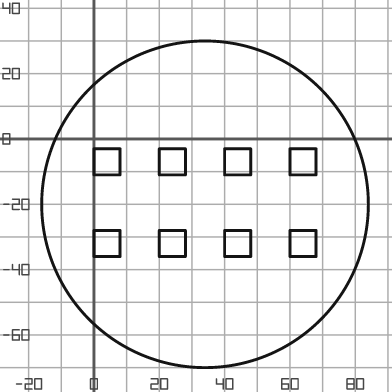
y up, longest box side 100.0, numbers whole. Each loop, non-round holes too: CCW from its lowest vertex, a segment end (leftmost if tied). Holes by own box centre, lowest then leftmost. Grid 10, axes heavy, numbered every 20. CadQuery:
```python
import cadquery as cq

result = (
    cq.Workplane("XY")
    .moveTo(34.0, -20.0)
    .circle(50.0)
    .moveTo(0.0, -36.0)
    .lineTo(8.0, -36.0)
    .lineTo(8.0, -28.0)
    .lineTo(0.0, -28.0)
    .close()
    .moveTo(20.0, -36.0)
    .lineTo(28.0, -36.0)
    .lineTo(28.0, -28.0)
    .lineTo(20.0, -28.0)
    .close()
    .moveTo(40.0, -36.0)
    .lineTo(48.0, -36.0)
    .lineTo(48.0, -28.0)
    .lineTo(40.0, -28.0)
    .close()
    .moveTo(60.0, -36.0)
    .lineTo(68.0, -36.0)
    .lineTo(68.0, -28.0)
    .lineTo(60.0, -28.0)
    .close()
    .moveTo(0.0, -11.0)
    .lineTo(8.0, -11.0)
    .lineTo(8.0, -3.0)
    .lineTo(0.0, -3.0)
    .close()
    .moveTo(20.0, -11.0)
    .lineTo(28.0, -11.0)
    .lineTo(28.0, -3.0)
    .lineTo(20.0, -3.0)
    .close()
    .moveTo(40.0, -11.0)
    .lineTo(48.0, -11.0)
    .lineTo(48.0, -3.0)
    .lineTo(40.0, -3.0)
    .close()
    .moveTo(60.0, -11.0)
    .lineTo(68.0, -11.0)
    .lineTo(68.0, -3.0)
    .lineTo(60.0, -3.0)
    .close()
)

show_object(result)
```